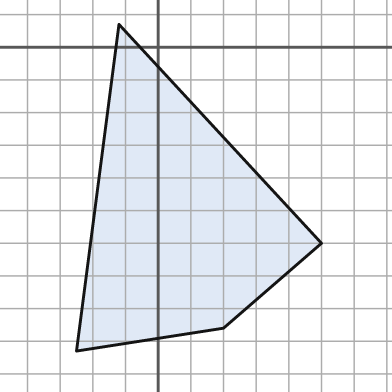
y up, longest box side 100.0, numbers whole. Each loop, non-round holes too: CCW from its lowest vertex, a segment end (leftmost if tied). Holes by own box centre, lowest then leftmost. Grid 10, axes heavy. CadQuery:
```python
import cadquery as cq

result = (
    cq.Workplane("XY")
    .moveTo(-25.0, -93.0)
    .lineTo(20.0, -86.0)
    .lineTo(50.0, -60.0)
    .lineTo(-12.0, 7.0)
    .close()
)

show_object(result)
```